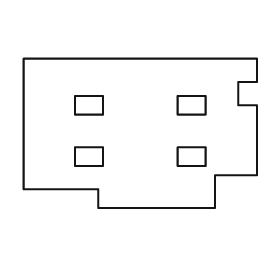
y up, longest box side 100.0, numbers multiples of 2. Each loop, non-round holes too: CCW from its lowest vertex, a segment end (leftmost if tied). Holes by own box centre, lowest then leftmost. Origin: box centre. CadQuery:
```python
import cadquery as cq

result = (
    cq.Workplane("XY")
    .moveTo(-18.0, -32.0)
    .lineTo(32.0, -32.0)
    .lineTo(32.0, -18.0)
    .lineTo(50.0, -18.0)
    .lineTo(50.0, 12.0)
    .lineTo(42.0, 12.0)
    .lineTo(42.0, 22.0)
    .lineTo(50.0, 22.0)
    .lineTo(50.0, 32.0)
    .lineTo(-50.0, 32.0)
    .lineTo(-50.0, -24.0)
    .lineTo(-18.0, -24.0)
    .close()
    .moveTo(-28.0, -14.0)
    .lineTo(-16.0, -14.0)
    .lineTo(-16.0, -6.0)
    .lineTo(-28.0, -6.0)
    .close()
    .moveTo(16.0, -14.0)
    .lineTo(28.0, -14.0)
    .lineTo(28.0, -6.0)
    .lineTo(16.0, -6.0)
    .close()
    .moveTo(-28.0, 8.0)
    .lineTo(-16.0, 8.0)
    .lineTo(-16.0, 16.0)
    .lineTo(-28.0, 16.0)
    .close()
    .moveTo(16.0, 8.0)
    .lineTo(28.0, 8.0)
    .lineTo(28.0, 16.0)
    .lineTo(16.0, 16.0)
    .close()
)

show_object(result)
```